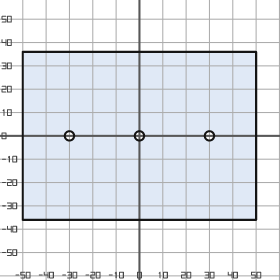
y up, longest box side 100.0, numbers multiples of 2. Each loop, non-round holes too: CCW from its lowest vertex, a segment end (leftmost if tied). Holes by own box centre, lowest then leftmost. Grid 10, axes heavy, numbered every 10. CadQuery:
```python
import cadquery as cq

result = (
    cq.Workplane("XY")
    .moveTo(-50.0, -36.0)
    .lineTo(50.0, -36.0)
    .lineTo(50.0, 36.0)
    .lineTo(-50.0, 36.0)
    .close()
    .moveTo(-30.0, 0.0)
    .circle(2.0)
    .moveTo(0.0, 0.0)
    .circle(2.0)
    .moveTo(30.0, 0.0)
    .circle(2.0)
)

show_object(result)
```